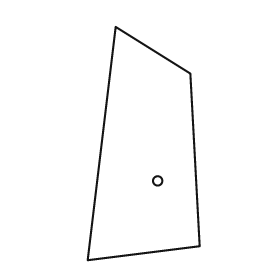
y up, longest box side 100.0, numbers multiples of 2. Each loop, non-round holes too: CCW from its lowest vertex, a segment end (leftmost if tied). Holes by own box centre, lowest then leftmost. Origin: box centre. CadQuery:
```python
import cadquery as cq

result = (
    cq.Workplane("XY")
    .moveTo(-24.0, -50.0)
    .lineTo(24.0, -44.0)
    .lineTo(20.0, 30.0)
    .lineTo(-12.0, 50.0)
    .close()
    .moveTo(6.0, -16.0)
    .circle(2.0)
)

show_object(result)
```